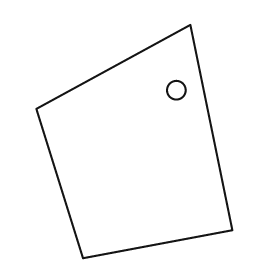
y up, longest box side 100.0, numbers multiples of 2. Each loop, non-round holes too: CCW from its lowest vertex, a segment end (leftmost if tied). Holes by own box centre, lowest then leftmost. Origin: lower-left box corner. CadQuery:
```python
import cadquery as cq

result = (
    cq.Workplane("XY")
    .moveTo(20.0, 0.0)
    .lineTo(84.0, 12.0)
    .lineTo(66.0, 100.0)
    .lineTo(0.0, 64.0)
    .close()
    .moveTo(60.0, 72.0)
    .circle(4.0)
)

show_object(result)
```